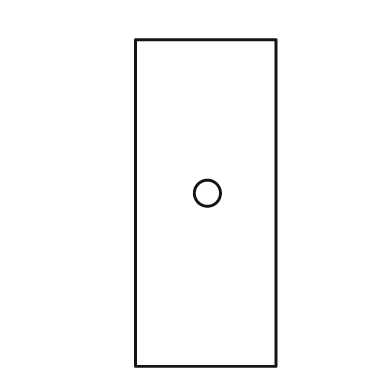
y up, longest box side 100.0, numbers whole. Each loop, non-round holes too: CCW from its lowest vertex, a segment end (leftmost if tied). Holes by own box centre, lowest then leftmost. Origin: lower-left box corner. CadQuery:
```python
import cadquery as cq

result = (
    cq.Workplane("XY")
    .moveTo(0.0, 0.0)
    .lineTo(43.0, 0.0)
    .lineTo(43.0, 100.0)
    .lineTo(0.0, 100.0)
    .close()
    .moveTo(22.0, 53.0)
    .circle(4.0)
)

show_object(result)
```